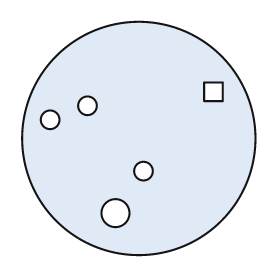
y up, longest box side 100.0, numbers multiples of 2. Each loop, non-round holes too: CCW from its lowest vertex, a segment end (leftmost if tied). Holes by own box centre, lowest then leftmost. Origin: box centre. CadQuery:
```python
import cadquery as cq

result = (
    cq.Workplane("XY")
    .moveTo(0.0, 0.0)
    .circle(50.0)
    .moveTo(-10.0, -32.0)
    .circle(6.0)
    .moveTo(2.0, -14.0)
    .circle(4.0)
    .moveTo(-38.0, 8.0)
    .circle(4.0)
    .moveTo(-22.0, 14.0)
    .circle(4.0)
    .moveTo(28.0, 16.0)
    .lineTo(36.0, 16.0)
    .lineTo(36.0, 24.0)
    .lineTo(28.0, 24.0)
    .close()
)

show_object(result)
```